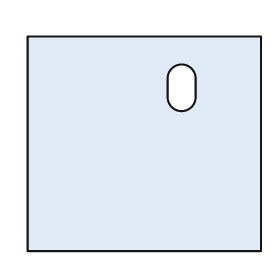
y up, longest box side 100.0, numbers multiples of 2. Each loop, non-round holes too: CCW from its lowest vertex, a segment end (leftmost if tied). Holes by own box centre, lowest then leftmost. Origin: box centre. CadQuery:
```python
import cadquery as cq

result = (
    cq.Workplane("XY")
    .moveTo(-50.0, -46.0)
    .lineTo(50.0, -46.0)
    .lineTo(50.0, 46.0)
    .lineTo(-50.0, 46.0)
    .close()
    .moveTo(10.0, 20.0)
    .threePointArc((16.0, 14.0), (22.0, 20.0))
    .lineTo(22.0, 28.0)
    .threePointArc((16.0, 34.0), (10.0, 28.0))
    .close()
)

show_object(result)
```